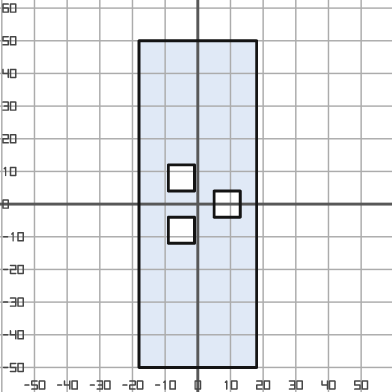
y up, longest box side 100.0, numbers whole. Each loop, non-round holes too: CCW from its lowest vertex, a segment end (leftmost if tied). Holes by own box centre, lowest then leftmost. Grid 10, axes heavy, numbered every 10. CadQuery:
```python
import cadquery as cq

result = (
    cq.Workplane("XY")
    .moveTo(-18.0, -50.0)
    .lineTo(18.0, -50.0)
    .lineTo(18.0, 50.0)
    .lineTo(-18.0, 50.0)
    .close()
    .moveTo(-9.0, -12.0)
    .lineTo(-1.0, -12.0)
    .lineTo(-1.0, -4.0)
    .lineTo(-9.0, -4.0)
    .close()
    .moveTo(5.0, -4.0)
    .lineTo(13.0, -4.0)
    .lineTo(13.0, 4.0)
    .lineTo(5.0, 4.0)
    .close()
    .moveTo(-9.0, 4.0)
    .lineTo(-1.0, 4.0)
    .lineTo(-1.0, 12.0)
    .lineTo(-9.0, 12.0)
    .close()
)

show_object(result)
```